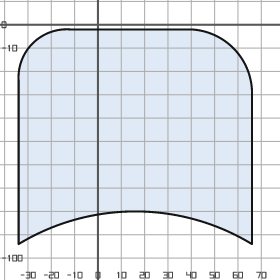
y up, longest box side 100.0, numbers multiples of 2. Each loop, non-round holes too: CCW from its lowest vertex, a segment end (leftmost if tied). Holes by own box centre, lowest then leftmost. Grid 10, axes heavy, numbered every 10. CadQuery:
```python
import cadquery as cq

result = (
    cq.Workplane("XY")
    .moveTo(-34.0, -94.0)
    .threePointArc((16.0, -80.0), (66.0, -94.0))
    .lineTo(66.0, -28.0)
    .threePointArc((58.0, -10.0), (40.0, -2.0))
    .lineTo(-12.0, -2.0)
    .threePointArc((-28.0, -8.0), (-34.0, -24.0))
    .close()
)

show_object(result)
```